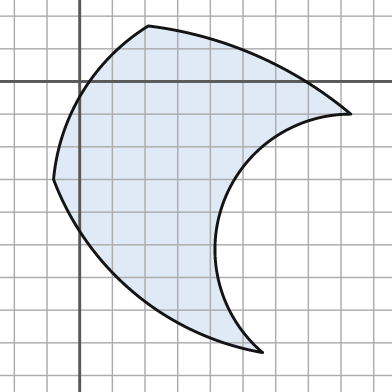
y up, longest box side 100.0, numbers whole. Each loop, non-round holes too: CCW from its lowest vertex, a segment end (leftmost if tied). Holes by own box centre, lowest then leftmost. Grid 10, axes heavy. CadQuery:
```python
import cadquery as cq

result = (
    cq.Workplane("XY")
    .moveTo(56.0, -83.0)
    .threePointArc((44.0, -37.0), (83.0, -10.0))
    .threePointArc((54.0, 8.0), (21.0, 17.0))
    .threePointArc((1.0, -3.0), (-8.0, -30.0))
    .threePointArc((17.0, -65.0), (56.0, -83.0))
    .close()
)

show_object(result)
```